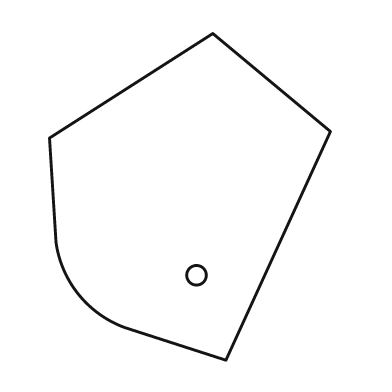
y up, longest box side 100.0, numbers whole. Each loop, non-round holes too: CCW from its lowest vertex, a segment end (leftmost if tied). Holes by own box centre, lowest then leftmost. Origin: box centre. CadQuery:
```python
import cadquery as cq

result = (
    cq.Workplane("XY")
    .moveTo(11.0, -50.0)
    .lineTo(43.0, 20.0)
    .lineTo(7.0, 50.0)
    .lineTo(-43.0, 18.0)
    .lineTo(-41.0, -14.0)
    .threePointArc((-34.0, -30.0), (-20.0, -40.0))
    .close()
    .moveTo(2.0, -24.0)
    .circle(3.0)
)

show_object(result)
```